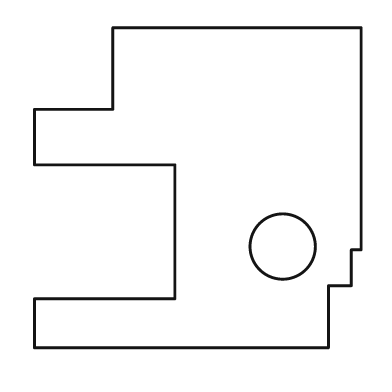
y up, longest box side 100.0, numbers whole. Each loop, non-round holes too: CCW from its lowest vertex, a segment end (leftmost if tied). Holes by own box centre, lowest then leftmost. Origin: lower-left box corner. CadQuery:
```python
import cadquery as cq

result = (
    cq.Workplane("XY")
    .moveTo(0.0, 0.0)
    .lineTo(90.0, 0.0)
    .lineTo(90.0, 19.0)
    .lineTo(97.0, 19.0)
    .lineTo(97.0, 30.0)
    .lineTo(100.0, 30.0)
    .lineTo(100.0, 98.0)
    .lineTo(24.0, 98.0)
    .lineTo(24.0, 73.0)
    .lineTo(0.0, 73.0)
    .lineTo(0.0, 56.0)
    .lineTo(43.0, 56.0)
    .lineTo(43.0, 15.0)
    .lineTo(0.0, 15.0)
    .close()
    .moveTo(76.0, 31.0)
    .circle(10.0)
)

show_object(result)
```